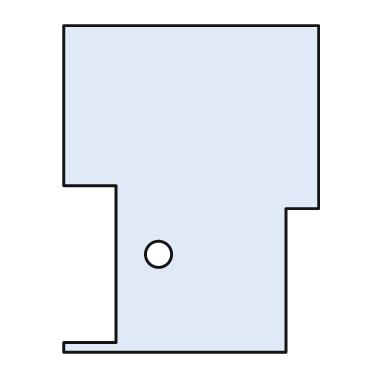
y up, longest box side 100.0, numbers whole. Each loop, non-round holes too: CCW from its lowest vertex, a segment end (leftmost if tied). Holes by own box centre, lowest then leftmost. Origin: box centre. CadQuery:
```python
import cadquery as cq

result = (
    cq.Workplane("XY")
    .moveTo(-39.0, -50.0)
    .lineTo(29.0, -50.0)
    .lineTo(29.0, -6.0)
    .lineTo(39.0, -6.0)
    .lineTo(39.0, 50.0)
    .lineTo(-39.0, 50.0)
    .lineTo(-39.0, 1.0)
    .lineTo(-23.0, 1.0)
    .lineTo(-23.0, -47.0)
    .lineTo(-39.0, -47.0)
    .close()
    .moveTo(-10.0, -20.0)
    .circle(4.0)
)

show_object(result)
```